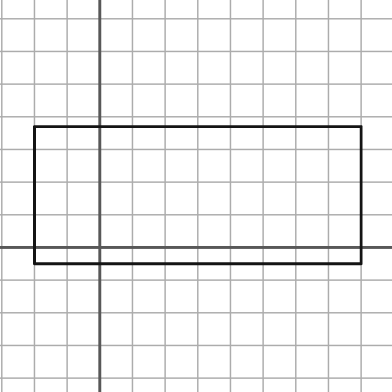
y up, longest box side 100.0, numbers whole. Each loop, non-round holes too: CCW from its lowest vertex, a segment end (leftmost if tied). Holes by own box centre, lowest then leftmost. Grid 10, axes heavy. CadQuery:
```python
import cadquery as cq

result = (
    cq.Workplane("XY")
    .moveTo(-20.0, -5.0)
    .lineTo(80.0, -5.0)
    .lineTo(80.0, 37.0)
    .lineTo(-20.0, 37.0)
    .close()
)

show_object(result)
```